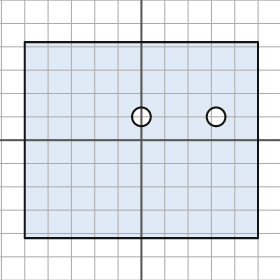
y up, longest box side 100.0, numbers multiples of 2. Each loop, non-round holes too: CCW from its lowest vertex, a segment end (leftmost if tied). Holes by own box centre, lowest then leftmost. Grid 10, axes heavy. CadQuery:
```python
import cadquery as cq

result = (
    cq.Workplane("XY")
    .moveTo(-50.0, -42.0)
    .lineTo(50.0, -42.0)
    .lineTo(50.0, 42.0)
    .lineTo(-50.0, 42.0)
    .close()
    .moveTo(0.0, 10.0)
    .circle(4.0)
    .moveTo(32.0, 10.0)
    .circle(4.0)
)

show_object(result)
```